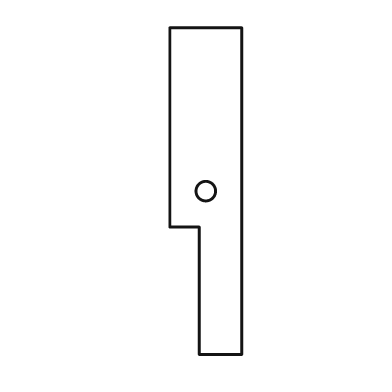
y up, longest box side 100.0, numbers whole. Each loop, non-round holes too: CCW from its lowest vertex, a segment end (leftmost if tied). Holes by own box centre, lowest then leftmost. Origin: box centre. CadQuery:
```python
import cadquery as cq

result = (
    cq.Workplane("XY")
    .moveTo(-2.0, -50.0)
    .lineTo(11.0, -50.0)
    .lineTo(11.0, 50.0)
    .lineTo(-11.0, 50.0)
    .lineTo(-11.0, -11.0)
    .lineTo(-2.0, -11.0)
    .close()
    .moveTo(0.0, 0.0)
    .circle(3.0)
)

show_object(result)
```